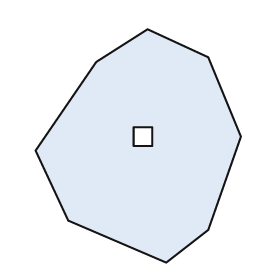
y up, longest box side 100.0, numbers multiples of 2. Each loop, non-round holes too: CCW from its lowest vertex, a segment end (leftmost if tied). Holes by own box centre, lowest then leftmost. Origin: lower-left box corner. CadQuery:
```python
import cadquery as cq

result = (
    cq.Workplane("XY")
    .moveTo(56.0, 0.0)
    .lineTo(74.0, 14.0)
    .lineTo(88.0, 54.0)
    .lineTo(74.0, 88.0)
    .lineTo(48.0, 100.0)
    .lineTo(26.0, 86.0)
    .lineTo(0.0, 48.0)
    .lineTo(14.0, 18.0)
    .close()
    .moveTo(42.0, 50.0)
    .lineTo(50.0, 50.0)
    .lineTo(50.0, 58.0)
    .lineTo(42.0, 58.0)
    .close()
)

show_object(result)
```